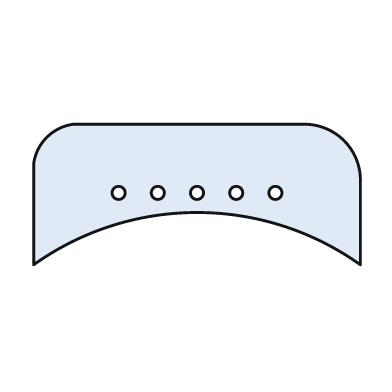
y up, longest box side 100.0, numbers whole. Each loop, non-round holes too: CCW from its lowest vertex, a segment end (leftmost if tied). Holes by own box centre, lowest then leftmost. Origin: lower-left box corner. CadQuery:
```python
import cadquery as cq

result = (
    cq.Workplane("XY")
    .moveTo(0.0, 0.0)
    .threePointArc((50.0, 16.0), (100.0, 0.0))
    .lineTo(100.0, 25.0)
    .threePointArc((95.0, 38.0), (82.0, 43.0))
    .lineTo(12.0, 43.0)
    .threePointArc((4.0, 39.0), (0.0, 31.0))
    .close()
    .moveTo(26.0, 22.0)
    .circle(2.0)
    .moveTo(38.0, 22.0)
    .circle(2.0)
    .moveTo(50.0, 22.0)
    .circle(2.0)
    .moveTo(62.0, 22.0)
    .circle(2.0)
    .moveTo(74.0, 22.0)
    .circle(2.0)
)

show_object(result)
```